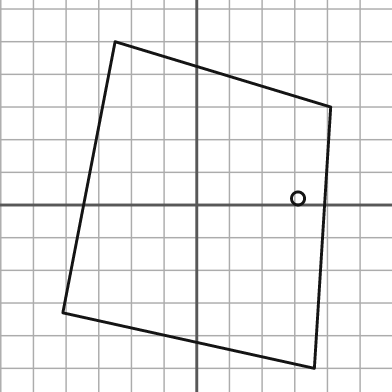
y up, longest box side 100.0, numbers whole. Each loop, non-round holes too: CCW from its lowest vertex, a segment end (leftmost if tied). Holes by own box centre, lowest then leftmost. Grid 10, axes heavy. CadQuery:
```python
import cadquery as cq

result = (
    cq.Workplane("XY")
    .moveTo(36.0, -50.0)
    .lineTo(41.0, 30.0)
    .lineTo(-25.0, 50.0)
    .lineTo(-41.0, -33.0)
    .close()
    .moveTo(31.0, 2.0)
    .circle(2.0)
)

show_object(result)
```